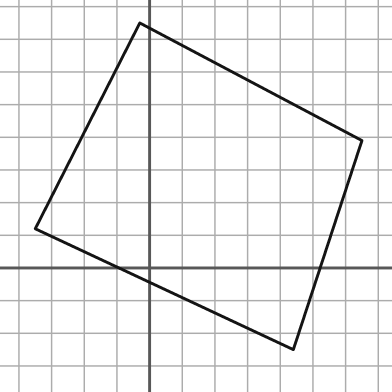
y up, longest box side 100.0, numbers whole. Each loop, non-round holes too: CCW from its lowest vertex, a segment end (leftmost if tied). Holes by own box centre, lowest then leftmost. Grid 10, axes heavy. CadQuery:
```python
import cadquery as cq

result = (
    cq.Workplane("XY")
    .moveTo(44.0, -25.0)
    .lineTo(65.0, 39.0)
    .lineTo(-3.0, 75.0)
    .lineTo(-35.0, 12.0)
    .close()
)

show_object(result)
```